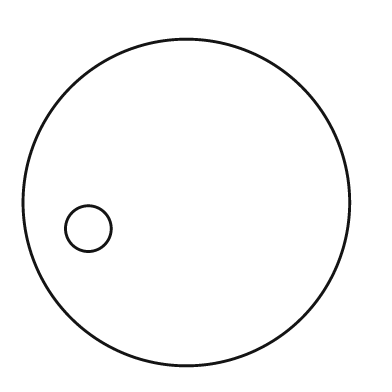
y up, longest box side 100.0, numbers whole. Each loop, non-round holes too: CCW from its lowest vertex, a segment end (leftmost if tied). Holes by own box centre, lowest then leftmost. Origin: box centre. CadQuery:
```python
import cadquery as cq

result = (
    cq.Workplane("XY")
    .moveTo(0.0, 0.0)
    .circle(50.0)
    .moveTo(-30.0, -8.0)
    .circle(7.0)
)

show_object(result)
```